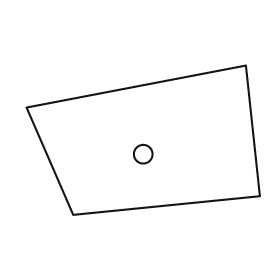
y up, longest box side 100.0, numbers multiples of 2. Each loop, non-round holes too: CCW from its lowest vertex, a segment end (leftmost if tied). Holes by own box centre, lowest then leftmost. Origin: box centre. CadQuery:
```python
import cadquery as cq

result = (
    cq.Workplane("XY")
    .moveTo(-30.0, -32.0)
    .lineTo(50.0, -24.0)
    .lineTo(44.0, 32.0)
    .lineTo(-50.0, 14.0)
    .close()
    .moveTo(0.0, -6.0)
    .circle(4.0)
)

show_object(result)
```